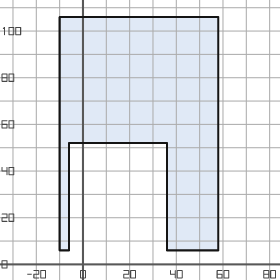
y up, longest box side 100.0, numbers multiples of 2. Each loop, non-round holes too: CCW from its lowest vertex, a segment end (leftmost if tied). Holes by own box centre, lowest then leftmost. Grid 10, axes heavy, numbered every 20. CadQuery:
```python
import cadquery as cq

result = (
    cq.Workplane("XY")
    .moveTo(-10.0, 6.0)
    .lineTo(-6.0, 6.0)
    .lineTo(-6.0, 52.0)
    .lineTo(36.0, 52.0)
    .lineTo(36.0, 6.0)
    .lineTo(58.0, 6.0)
    .lineTo(58.0, 106.0)
    .lineTo(-10.0, 106.0)
    .close()
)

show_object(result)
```